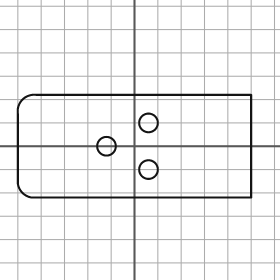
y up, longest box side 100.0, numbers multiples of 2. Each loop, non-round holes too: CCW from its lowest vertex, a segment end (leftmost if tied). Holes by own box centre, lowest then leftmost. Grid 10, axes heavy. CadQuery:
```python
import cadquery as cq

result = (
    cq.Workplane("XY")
    .moveTo(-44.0, -22.0)
    .lineTo(50.0, -22.0)
    .lineTo(50.0, 22.0)
    .lineTo(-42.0, 22.0)
    .threePointArc((-48.0, 20.0), (-50.0, 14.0))
    .lineTo(-50.0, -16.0)
    .threePointArc((-48.0, -20.0), (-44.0, -22.0))
    .close()
    .moveTo(6.0, -10.0)
    .circle(4.0)
    .moveTo(-12.0, 0.0)
    .circle(4.0)
    .moveTo(6.0, 10.0)
    .circle(4.0)
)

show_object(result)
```